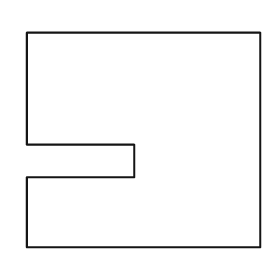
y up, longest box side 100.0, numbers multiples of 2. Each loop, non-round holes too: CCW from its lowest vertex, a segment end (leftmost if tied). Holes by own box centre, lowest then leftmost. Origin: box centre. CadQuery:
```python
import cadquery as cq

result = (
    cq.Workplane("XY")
    .moveTo(-50.0, -46.0)
    .lineTo(50.0, -46.0)
    .lineTo(50.0, 46.0)
    .lineTo(-50.0, 46.0)
    .lineTo(-50.0, -2.0)
    .lineTo(-4.0, -2.0)
    .lineTo(-4.0, -16.0)
    .lineTo(-50.0, -16.0)
    .close()
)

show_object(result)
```